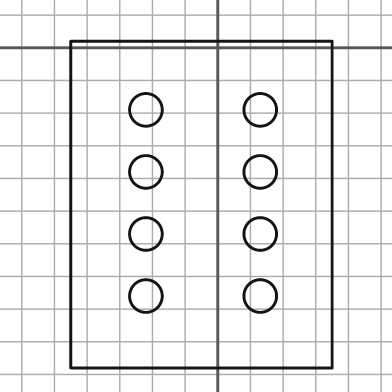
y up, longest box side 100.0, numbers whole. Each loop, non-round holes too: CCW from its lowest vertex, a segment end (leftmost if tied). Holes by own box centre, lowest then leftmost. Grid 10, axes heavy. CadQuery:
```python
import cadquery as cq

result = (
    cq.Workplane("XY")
    .moveTo(-45.0, -98.0)
    .lineTo(35.0, -98.0)
    .lineTo(35.0, 2.0)
    .lineTo(-45.0, 2.0)
    .close()
    .moveTo(-22.0, -76.0)
    .circle(5.0)
    .moveTo(13.0, -76.0)
    .circle(5.0)
    .moveTo(-22.0, -57.0)
    .circle(5.0)
    .moveTo(13.0, -57.0)
    .circle(5.0)
    .moveTo(-22.0, -38.0)
    .circle(5.0)
    .moveTo(13.0, -38.0)
    .circle(5.0)
    .moveTo(-22.0, -19.0)
    .circle(5.0)
    .moveTo(13.0, -19.0)
    .circle(5.0)
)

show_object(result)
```